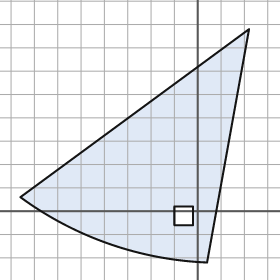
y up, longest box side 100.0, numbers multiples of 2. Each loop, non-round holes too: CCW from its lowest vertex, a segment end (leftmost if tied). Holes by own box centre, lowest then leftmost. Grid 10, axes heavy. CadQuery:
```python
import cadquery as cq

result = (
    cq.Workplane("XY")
    .moveTo(4.0, -22.0)
    .lineTo(22.0, 78.0)
    .lineTo(-76.0, 6.0)
    .threePointArc((-38.0, -14.0), (4.0, -22.0))
    .close()
    .moveTo(-10.0, -6.0)
    .lineTo(-2.0, -6.0)
    .lineTo(-2.0, 2.0)
    .lineTo(-10.0, 2.0)
    .close()
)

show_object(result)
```